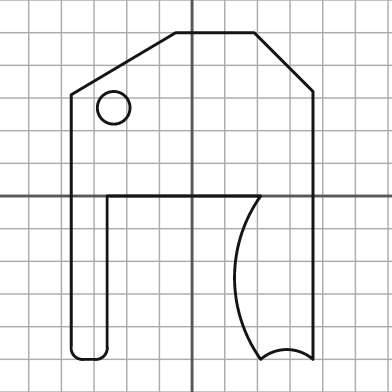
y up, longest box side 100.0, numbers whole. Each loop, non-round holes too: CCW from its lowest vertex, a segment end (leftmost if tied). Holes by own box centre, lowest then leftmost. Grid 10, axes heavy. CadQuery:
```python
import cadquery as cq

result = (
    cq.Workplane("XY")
    .moveTo(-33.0, -50.0)
    .lineTo(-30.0, -50.0)
    .threePointArc((-27.0, -49.0), (-26.0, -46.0))
    .lineTo(-26.0, 0.0)
    .lineTo(21.0, 0.0)
    .threePointArc((13.0, -25.0), (21.0, -50.0))
    .threePointArc((29.0, -47.0), (37.0, -50.0))
    .lineTo(37.0, 32.0)
    .lineTo(19.0, 50.0)
    .lineTo(-5.0, 50.0)
    .lineTo(-37.0, 31.0)
    .lineTo(-37.0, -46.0)
    .threePointArc((-36.0, -49.0), (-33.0, -50.0))
    .close()
    .moveTo(-24.0, 27.0)
    .circle(5.0)
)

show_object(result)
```